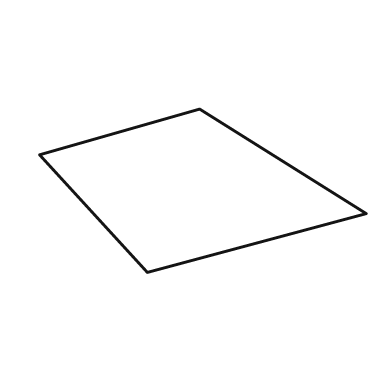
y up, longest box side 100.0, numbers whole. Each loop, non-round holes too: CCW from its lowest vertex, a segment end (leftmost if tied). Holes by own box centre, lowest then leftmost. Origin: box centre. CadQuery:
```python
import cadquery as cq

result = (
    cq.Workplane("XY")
    .moveTo(-17.0, -25.0)
    .lineTo(50.0, -7.0)
    .lineTo(-1.0, 25.0)
    .lineTo(-50.0, 11.0)
    .close()
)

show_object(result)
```